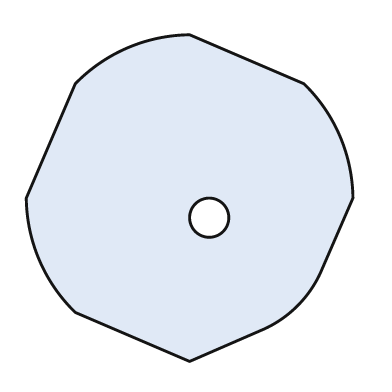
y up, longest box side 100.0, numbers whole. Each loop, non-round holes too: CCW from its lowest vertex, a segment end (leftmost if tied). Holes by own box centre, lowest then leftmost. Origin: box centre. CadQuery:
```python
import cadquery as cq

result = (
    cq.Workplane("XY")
    .moveTo(0.0, -50.0)
    .lineTo(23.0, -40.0)
    .threePointArc((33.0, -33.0), (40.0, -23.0))
    .lineTo(50.0, 0.0)
    .threePointArc((46.0, 19.0), (35.0, 35.0))
    .lineTo(0.0, 50.0)
    .threePointArc((-19.0, 46.0), (-35.0, 35.0))
    .lineTo(-50.0, 0.0)
    .threePointArc((-46.0, -19.0), (-35.0, -35.0))
    .close()
    .moveTo(6.0, -6.0)
    .circle(6.0)
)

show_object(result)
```